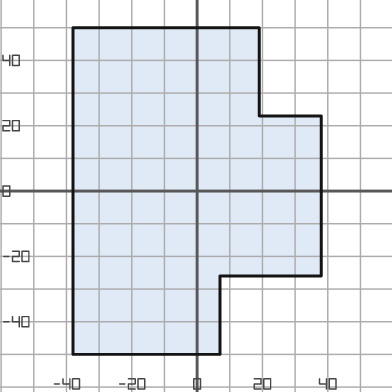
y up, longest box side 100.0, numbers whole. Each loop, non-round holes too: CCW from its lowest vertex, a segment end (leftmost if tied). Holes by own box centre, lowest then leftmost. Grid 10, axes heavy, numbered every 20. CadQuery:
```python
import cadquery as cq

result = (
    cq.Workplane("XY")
    .moveTo(-38.0, -50.0)
    .lineTo(7.0, -50.0)
    .lineTo(7.0, -26.0)
    .lineTo(38.0, -26.0)
    .lineTo(38.0, 23.0)
    .lineTo(19.0, 23.0)
    .lineTo(19.0, 50.0)
    .lineTo(-38.0, 50.0)
    .close()
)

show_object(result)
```